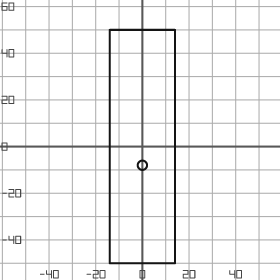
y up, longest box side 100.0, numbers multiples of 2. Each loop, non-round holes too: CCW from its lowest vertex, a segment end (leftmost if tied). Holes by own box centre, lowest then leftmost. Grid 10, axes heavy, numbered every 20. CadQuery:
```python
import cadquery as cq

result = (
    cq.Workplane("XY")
    .moveTo(-14.0, -50.0)
    .lineTo(14.0, -50.0)
    .lineTo(14.0, 50.0)
    .lineTo(-14.0, 50.0)
    .close()
    .moveTo(0.0, -8.0)
    .circle(2.0)
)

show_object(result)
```